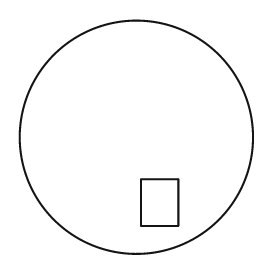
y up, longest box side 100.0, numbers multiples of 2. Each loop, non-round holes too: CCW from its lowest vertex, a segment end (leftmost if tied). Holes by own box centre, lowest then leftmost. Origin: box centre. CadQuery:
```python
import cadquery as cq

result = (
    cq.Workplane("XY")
    .moveTo(0.0, 0.0)
    .circle(50.0)
    .moveTo(2.0, -38.0)
    .lineTo(18.0, -38.0)
    .lineTo(18.0, -18.0)
    .lineTo(2.0, -18.0)
    .close()
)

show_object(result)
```